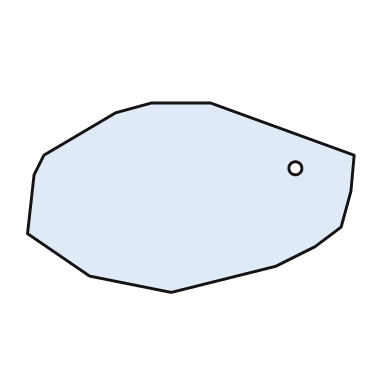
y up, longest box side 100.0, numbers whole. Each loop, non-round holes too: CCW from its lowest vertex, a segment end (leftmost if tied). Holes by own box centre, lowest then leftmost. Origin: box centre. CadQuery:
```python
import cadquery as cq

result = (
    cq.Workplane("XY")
    .moveTo(-6.0, -29.0)
    .lineTo(26.0, -21.0)
    .lineTo(38.0, -15.0)
    .lineTo(46.0, -9.0)
    .lineTo(49.0, 2.0)
    .lineTo(50.0, 13.0)
    .lineTo(6.0, 29.0)
    .lineTo(-12.0, 29.0)
    .lineTo(-23.0, 26.0)
    .lineTo(-45.0, 13.0)
    .lineTo(-48.0, 7.0)
    .lineTo(-50.0, -11.0)
    .lineTo(-31.0, -24.0)
    .close()
    .moveTo(32.0, 9.0)
    .circle(2.0)
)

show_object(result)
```